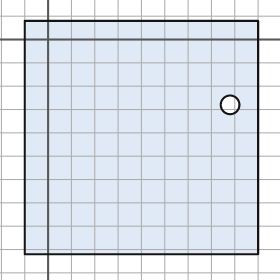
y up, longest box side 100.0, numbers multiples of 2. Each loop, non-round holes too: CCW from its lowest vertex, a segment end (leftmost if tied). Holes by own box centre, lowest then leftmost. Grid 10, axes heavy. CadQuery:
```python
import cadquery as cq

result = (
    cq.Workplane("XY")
    .moveTo(-10.0, -92.0)
    .lineTo(90.0, -92.0)
    .lineTo(90.0, 8.0)
    .lineTo(-10.0, 8.0)
    .close()
    .moveTo(78.0, -28.0)
    .circle(4.0)
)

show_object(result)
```